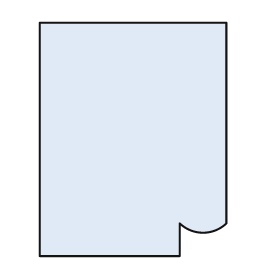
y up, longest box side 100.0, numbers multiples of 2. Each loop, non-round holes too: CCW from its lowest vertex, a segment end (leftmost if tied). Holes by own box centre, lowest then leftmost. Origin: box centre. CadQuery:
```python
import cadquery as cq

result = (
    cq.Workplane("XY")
    .moveTo(-40.0, -50.0)
    .lineTo(20.0, -50.0)
    .lineTo(20.0, -36.0)
    .threePointArc((30.0, -40.0), (40.0, -36.0))
    .lineTo(40.0, 50.0)
    .lineTo(-40.0, 50.0)
    .close()
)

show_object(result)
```